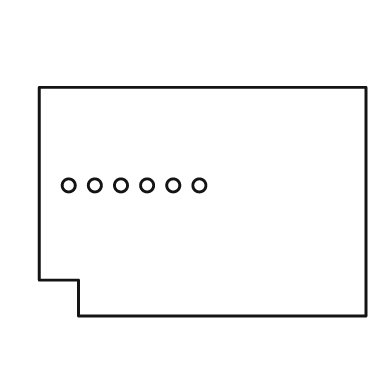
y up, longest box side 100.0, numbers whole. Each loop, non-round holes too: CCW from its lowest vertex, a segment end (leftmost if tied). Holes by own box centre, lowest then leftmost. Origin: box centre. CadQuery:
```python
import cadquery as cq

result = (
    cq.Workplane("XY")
    .moveTo(-38.0, -35.0)
    .lineTo(50.0, -35.0)
    .lineTo(50.0, 35.0)
    .lineTo(-50.0, 35.0)
    .lineTo(-50.0, -24.0)
    .lineTo(-38.0, -24.0)
    .close()
    .moveTo(-41.0, 5.0)
    .circle(2.0)
    .moveTo(-33.0, 5.0)
    .circle(2.0)
    .moveTo(-25.0, 5.0)
    .circle(2.0)
    .moveTo(-17.0, 5.0)
    .circle(2.0)
    .moveTo(-9.0, 5.0)
    .circle(2.0)
    .moveTo(-1.0, 5.0)
    .circle(2.0)
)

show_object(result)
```